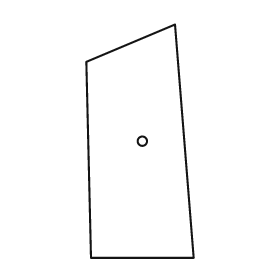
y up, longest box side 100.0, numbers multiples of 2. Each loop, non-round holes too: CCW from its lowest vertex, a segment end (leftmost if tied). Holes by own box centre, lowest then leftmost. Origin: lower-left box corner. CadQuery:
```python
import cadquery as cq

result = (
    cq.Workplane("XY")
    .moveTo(2.0, 0.0)
    .lineTo(46.0, 0.0)
    .lineTo(38.0, 100.0)
    .lineTo(0.0, 84.0)
    .close()
    .moveTo(24.0, 50.0)
    .circle(2.0)
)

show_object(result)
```